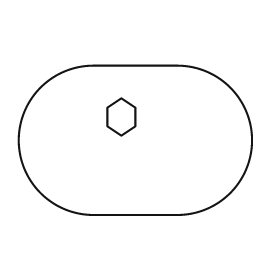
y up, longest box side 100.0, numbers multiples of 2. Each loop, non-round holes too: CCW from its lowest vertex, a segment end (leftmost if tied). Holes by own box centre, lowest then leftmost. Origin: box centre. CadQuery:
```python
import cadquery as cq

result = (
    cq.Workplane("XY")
    .moveTo(-18.0, -32.0)
    .lineTo(18.0, -32.0)
    .threePointArc((50.0, 0.0), (18.0, 32.0))
    .lineTo(-18.0, 32.0)
    .threePointArc((-50.0, 0.0), (-18.0, -32.0))
    .close()
    .moveTo(-6.0, 2.0)
    .lineTo(0.0, 6.0)
    .lineTo(0.0, 14.0)
    .lineTo(-6.0, 18.0)
    .lineTo(-12.0, 14.0)
    .lineTo(-12.0, 6.0)
    .close()
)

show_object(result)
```